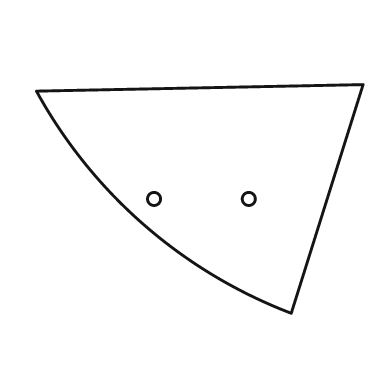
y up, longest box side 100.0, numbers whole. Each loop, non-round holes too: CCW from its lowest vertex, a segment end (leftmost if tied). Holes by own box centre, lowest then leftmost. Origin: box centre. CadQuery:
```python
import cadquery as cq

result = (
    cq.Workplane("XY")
    .moveTo(28.0, -35.0)
    .lineTo(50.0, 35.0)
    .lineTo(-50.0, 33.0)
    .threePointArc((-17.0, -8.0), (28.0, -35.0))
    .close()
    .moveTo(-14.0, 0.0)
    .circle(2.0)
    .moveTo(15.0, 0.0)
    .circle(2.0)
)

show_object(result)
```